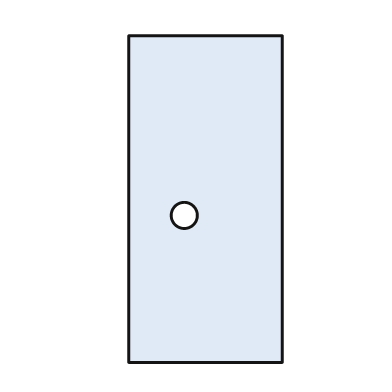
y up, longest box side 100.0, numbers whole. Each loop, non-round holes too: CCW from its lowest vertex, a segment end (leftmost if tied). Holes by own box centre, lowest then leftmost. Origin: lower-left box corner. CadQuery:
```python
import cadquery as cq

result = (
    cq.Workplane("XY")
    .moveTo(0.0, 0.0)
    .lineTo(47.0, 0.0)
    .lineTo(47.0, 100.0)
    .lineTo(0.0, 100.0)
    .close()
    .moveTo(17.0, 45.0)
    .circle(4.0)
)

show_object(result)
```